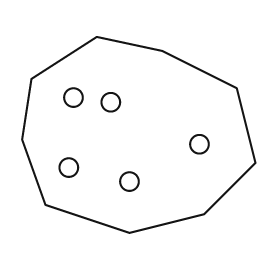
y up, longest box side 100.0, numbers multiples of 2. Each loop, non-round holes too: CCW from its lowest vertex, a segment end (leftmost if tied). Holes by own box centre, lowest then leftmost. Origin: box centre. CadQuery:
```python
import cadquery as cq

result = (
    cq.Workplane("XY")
    .moveTo(-4.0, -42.0)
    .lineTo(28.0, -34.0)
    .lineTo(50.0, -12.0)
    .lineTo(42.0, 20.0)
    .lineTo(10.0, 36.0)
    .lineTo(-18.0, 42.0)
    .lineTo(-46.0, 24.0)
    .lineTo(-50.0, -2.0)
    .lineTo(-40.0, -30.0)
    .close()
    .moveTo(-4.0, -20.0)
    .circle(4.0)
    .moveTo(-30.0, -14.0)
    .circle(4.0)
    .moveTo(26.0, -4.0)
    .circle(4.0)
    .moveTo(-12.0, 14.0)
    .circle(4.0)
    .moveTo(-28.0, 16.0)
    .circle(4.0)
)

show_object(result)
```